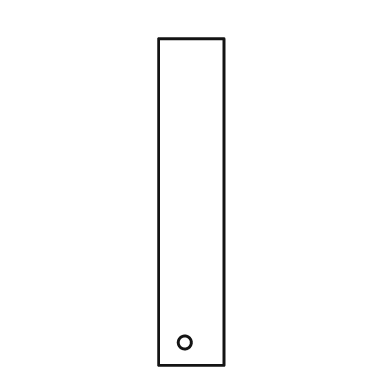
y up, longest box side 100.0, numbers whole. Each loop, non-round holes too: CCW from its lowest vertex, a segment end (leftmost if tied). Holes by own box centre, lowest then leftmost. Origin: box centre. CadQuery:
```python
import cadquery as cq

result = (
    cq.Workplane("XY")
    .moveTo(-10.0, -50.0)
    .lineTo(10.0, -50.0)
    .lineTo(10.0, 50.0)
    .lineTo(-10.0, 50.0)
    .close()
    .moveTo(-2.0, -43.0)
    .circle(2.0)
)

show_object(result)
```